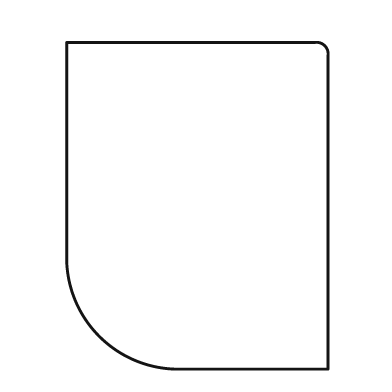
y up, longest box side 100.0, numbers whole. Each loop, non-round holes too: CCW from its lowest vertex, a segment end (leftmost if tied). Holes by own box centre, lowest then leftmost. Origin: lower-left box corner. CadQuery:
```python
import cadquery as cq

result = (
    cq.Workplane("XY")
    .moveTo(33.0, 0.0)
    .lineTo(80.0, 0.0)
    .lineTo(80.0, 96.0)
    .threePointArc((79.0, 99.0), (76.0, 100.0))
    .lineTo(0.0, 100.0)
    .lineTo(0.0, 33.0)
    .threePointArc((10.0, 10.0), (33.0, 0.0))
    .close()
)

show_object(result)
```